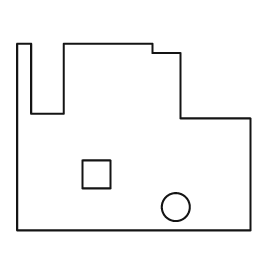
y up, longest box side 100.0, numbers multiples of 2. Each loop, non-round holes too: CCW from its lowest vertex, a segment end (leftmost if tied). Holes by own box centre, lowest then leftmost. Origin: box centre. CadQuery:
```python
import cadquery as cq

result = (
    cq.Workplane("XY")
    .moveTo(-50.0, -40.0)
    .lineTo(50.0, -40.0)
    .lineTo(50.0, 8.0)
    .lineTo(20.0, 8.0)
    .lineTo(20.0, 36.0)
    .lineTo(8.0, 36.0)
    .lineTo(8.0, 40.0)
    .lineTo(-30.0, 40.0)
    .lineTo(-30.0, 10.0)
    .lineTo(-44.0, 10.0)
    .lineTo(-44.0, 40.0)
    .lineTo(-50.0, 40.0)
    .close()
    .moveTo(18.0, -30.0)
    .circle(6.0)
    .moveTo(-22.0, -22.0)
    .lineTo(-10.0, -22.0)
    .lineTo(-10.0, -10.0)
    .lineTo(-22.0, -10.0)
    .close()
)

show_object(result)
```